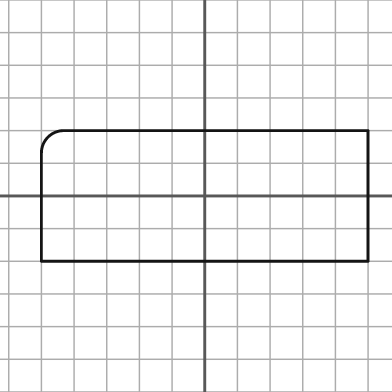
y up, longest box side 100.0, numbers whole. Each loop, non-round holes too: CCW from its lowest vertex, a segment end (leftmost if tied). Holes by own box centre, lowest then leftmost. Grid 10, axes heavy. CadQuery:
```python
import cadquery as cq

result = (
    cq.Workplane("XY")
    .moveTo(-50.0, -20.0)
    .lineTo(50.0, -20.0)
    .lineTo(50.0, 20.0)
    .lineTo(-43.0, 20.0)
    .threePointArc((-48.0, 18.0), (-50.0, 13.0))
    .close()
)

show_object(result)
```